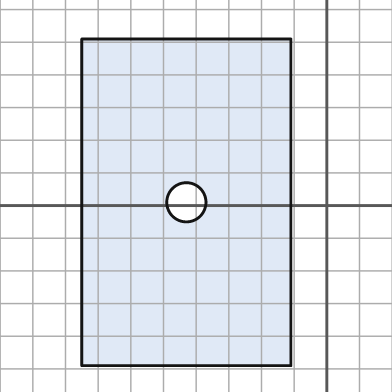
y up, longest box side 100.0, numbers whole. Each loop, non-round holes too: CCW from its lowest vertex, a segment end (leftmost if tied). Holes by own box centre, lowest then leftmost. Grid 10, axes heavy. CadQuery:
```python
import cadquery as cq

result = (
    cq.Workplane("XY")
    .moveTo(-75.0, -49.0)
    .lineTo(-11.0, -49.0)
    .lineTo(-11.0, 51.0)
    .lineTo(-75.0, 51.0)
    .close()
    .moveTo(-43.0, 1.0)
    .circle(6.0)
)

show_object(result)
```